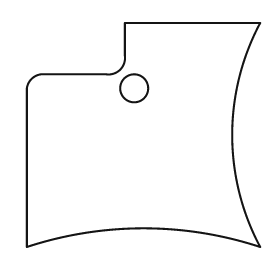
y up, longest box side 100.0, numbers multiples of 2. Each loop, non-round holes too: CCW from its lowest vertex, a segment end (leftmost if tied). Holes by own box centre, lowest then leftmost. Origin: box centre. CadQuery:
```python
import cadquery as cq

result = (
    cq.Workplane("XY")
    .moveTo(-50.0, -48.0)
    .threePointArc((0.0, -40.0), (50.0, -48.0))
    .threePointArc((38.0, 0.0), (50.0, 48.0))
    .lineTo(-8.0, 48.0)
    .lineTo(-8.0, 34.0)
    .threePointArc((-10.0, 28.0), (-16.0, 26.0))
    .lineTo(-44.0, 26.0)
    .threePointArc((-48.0, 24.0), (-50.0, 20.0))
    .close()
    .moveTo(-4.0, 20.0)
    .circle(6.0)
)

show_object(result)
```